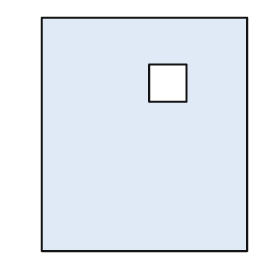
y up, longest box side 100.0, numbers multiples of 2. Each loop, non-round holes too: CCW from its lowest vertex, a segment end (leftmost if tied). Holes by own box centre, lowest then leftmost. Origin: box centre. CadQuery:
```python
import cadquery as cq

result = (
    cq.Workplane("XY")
    .moveTo(-44.0, -50.0)
    .lineTo(44.0, -50.0)
    .lineTo(44.0, 50.0)
    .lineTo(-44.0, 50.0)
    .close()
    .moveTo(2.0, 14.0)
    .lineTo(18.0, 14.0)
    .lineTo(18.0, 30.0)
    .lineTo(2.0, 30.0)
    .close()
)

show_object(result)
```